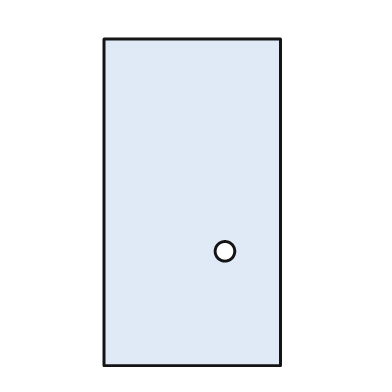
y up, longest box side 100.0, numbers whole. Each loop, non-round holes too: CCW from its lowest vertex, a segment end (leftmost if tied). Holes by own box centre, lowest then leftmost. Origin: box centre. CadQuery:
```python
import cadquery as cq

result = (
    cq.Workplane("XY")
    .moveTo(-27.0, -50.0)
    .lineTo(27.0, -50.0)
    .lineTo(27.0, 50.0)
    .lineTo(-27.0, 50.0)
    .close()
    .moveTo(10.0, -15.0)
    .circle(3.0)
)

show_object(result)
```